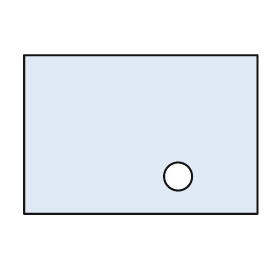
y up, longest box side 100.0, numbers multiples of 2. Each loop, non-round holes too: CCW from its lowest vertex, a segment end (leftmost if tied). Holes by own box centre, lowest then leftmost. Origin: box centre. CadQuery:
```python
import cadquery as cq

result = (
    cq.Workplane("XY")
    .moveTo(-50.0, -34.0)
    .lineTo(50.0, -34.0)
    .lineTo(50.0, 34.0)
    .lineTo(-50.0, 34.0)
    .close()
    .moveTo(16.0, -18.0)
    .circle(6.0)
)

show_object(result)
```